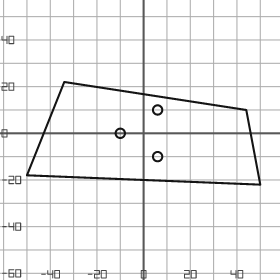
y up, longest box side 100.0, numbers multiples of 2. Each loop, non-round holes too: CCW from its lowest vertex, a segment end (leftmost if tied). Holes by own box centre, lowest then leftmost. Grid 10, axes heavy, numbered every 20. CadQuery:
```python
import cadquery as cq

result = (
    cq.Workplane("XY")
    .moveTo(50.0, -22.0)
    .lineTo(44.0, 10.0)
    .lineTo(-34.0, 22.0)
    .lineTo(-50.0, -18.0)
    .close()
    .moveTo(6.0, -10.0)
    .circle(2.0)
    .moveTo(-10.0, 0.0)
    .circle(2.0)
    .moveTo(6.0, 10.0)
    .circle(2.0)
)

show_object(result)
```